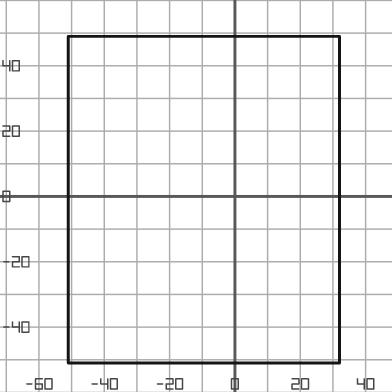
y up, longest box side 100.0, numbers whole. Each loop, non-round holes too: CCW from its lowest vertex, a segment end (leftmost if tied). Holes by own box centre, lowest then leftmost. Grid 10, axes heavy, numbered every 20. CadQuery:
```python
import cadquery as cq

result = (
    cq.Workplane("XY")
    .moveTo(-51.0, -51.0)
    .lineTo(32.0, -51.0)
    .lineTo(32.0, 49.0)
    .lineTo(-51.0, 49.0)
    .close()
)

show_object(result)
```